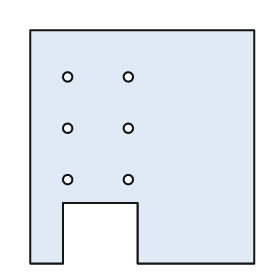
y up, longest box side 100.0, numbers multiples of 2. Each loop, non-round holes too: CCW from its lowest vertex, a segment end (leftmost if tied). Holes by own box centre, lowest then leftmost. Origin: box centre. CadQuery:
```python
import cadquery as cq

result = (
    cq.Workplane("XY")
    .moveTo(-48.0, -50.0)
    .lineTo(-34.0, -50.0)
    .lineTo(-34.0, -24.0)
    .lineTo(-2.0, -24.0)
    .lineTo(-2.0, -50.0)
    .lineTo(48.0, -50.0)
    .lineTo(48.0, 50.0)
    .lineTo(-48.0, 50.0)
    .close()
    .moveTo(-32.0, -14.0)
    .circle(2.0)
    .moveTo(-6.0, -14.0)
    .circle(2.0)
    .moveTo(-32.0, 8.0)
    .circle(2.0)
    .moveTo(-6.0, 8.0)
    .circle(2.0)
    .moveTo(-32.0, 30.0)
    .circle(2.0)
    .moveTo(-6.0, 30.0)
    .circle(2.0)
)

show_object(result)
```